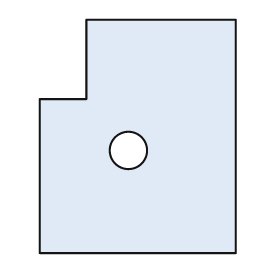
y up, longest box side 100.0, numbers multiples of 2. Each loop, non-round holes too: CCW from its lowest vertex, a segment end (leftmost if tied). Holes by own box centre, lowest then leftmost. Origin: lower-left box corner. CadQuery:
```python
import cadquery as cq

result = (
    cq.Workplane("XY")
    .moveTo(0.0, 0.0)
    .lineTo(84.0, 0.0)
    .lineTo(84.0, 100.0)
    .lineTo(20.0, 100.0)
    .lineTo(20.0, 66.0)
    .lineTo(0.0, 66.0)
    .close()
    .moveTo(38.0, 44.0)
    .circle(8.0)
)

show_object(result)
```